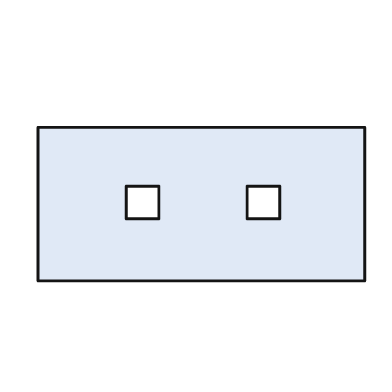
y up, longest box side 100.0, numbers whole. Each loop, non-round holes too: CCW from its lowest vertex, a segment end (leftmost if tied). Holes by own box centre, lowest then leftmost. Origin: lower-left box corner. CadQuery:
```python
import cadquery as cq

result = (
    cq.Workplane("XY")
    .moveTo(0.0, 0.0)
    .lineTo(100.0, 0.0)
    .lineTo(100.0, 47.0)
    .lineTo(0.0, 47.0)
    .close()
    .moveTo(27.0, 19.0)
    .lineTo(37.0, 19.0)
    .lineTo(37.0, 29.0)
    .lineTo(27.0, 29.0)
    .close()
    .moveTo(64.0, 19.0)
    .lineTo(74.0, 19.0)
    .lineTo(74.0, 29.0)
    .lineTo(64.0, 29.0)
    .close()
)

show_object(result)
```